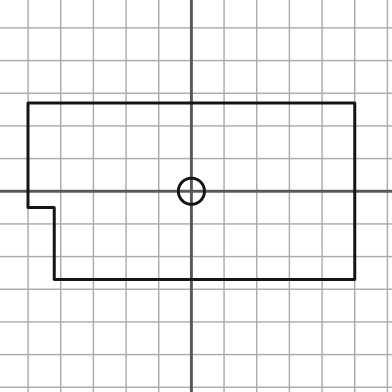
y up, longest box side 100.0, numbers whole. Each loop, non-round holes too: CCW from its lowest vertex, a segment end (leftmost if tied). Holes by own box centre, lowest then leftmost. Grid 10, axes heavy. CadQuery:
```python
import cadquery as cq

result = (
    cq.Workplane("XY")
    .moveTo(-42.0, -27.0)
    .lineTo(50.0, -27.0)
    .lineTo(50.0, 27.0)
    .lineTo(-50.0, 27.0)
    .lineTo(-50.0, -5.0)
    .lineTo(-42.0, -5.0)
    .close()
    .moveTo(0.0, 0.0)
    .circle(4.0)
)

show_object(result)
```